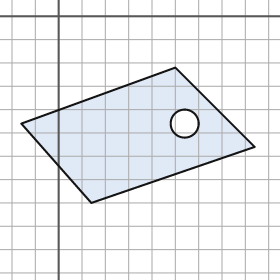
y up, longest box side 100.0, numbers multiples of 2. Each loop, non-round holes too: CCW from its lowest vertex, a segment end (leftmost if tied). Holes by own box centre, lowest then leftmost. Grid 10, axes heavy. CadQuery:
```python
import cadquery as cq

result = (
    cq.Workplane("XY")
    .moveTo(14.0, -80.0)
    .lineTo(84.0, -56.0)
    .lineTo(50.0, -22.0)
    .lineTo(-16.0, -46.0)
    .close()
    .moveTo(54.0, -46.0)
    .circle(6.0)
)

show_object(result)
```